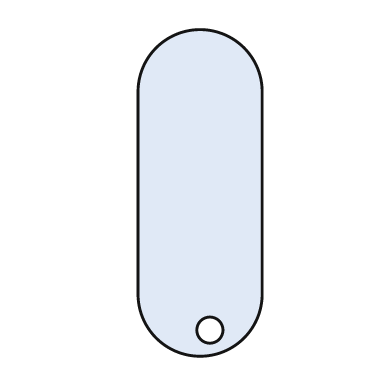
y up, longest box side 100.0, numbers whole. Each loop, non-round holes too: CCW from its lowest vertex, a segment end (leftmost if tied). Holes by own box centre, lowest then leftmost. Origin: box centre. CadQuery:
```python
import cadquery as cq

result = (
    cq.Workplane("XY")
    .moveTo(-19.0, -31.0)
    .threePointArc((0.0, -50.0), (19.0, -31.0))
    .lineTo(19.0, 31.0)
    .threePointArc((0.0, 50.0), (-19.0, 31.0))
    .close()
    .moveTo(3.0, -42.0)
    .circle(4.0)
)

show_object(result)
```